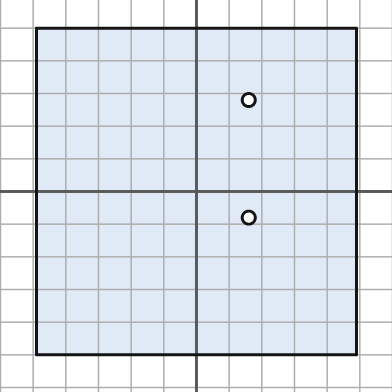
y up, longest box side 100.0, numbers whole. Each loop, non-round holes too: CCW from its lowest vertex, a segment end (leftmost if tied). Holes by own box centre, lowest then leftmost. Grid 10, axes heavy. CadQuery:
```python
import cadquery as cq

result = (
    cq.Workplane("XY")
    .moveTo(-49.0, -50.0)
    .lineTo(49.0, -50.0)
    .lineTo(49.0, 50.0)
    .lineTo(-49.0, 50.0)
    .close()
    .moveTo(16.0, -8.0)
    .circle(2.0)
    .moveTo(16.0, 28.0)
    .circle(2.0)
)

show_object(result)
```